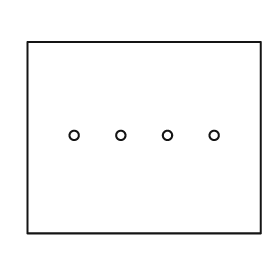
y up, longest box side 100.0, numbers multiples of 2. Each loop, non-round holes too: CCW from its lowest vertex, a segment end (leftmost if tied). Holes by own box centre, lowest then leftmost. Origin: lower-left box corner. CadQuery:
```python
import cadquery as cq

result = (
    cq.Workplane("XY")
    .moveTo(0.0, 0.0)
    .lineTo(100.0, 0.0)
    .lineTo(100.0, 82.0)
    .lineTo(0.0, 82.0)
    .close()
    .moveTo(20.0, 42.0)
    .circle(2.0)
    .moveTo(40.0, 42.0)
    .circle(2.0)
    .moveTo(60.0, 42.0)
    .circle(2.0)
    .moveTo(80.0, 42.0)
    .circle(2.0)
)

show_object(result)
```